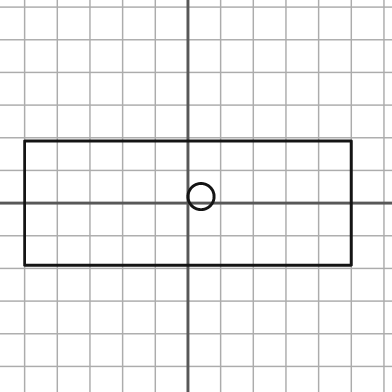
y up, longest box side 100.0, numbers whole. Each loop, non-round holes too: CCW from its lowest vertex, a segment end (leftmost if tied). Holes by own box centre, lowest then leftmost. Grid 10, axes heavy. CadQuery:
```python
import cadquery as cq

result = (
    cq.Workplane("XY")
    .moveTo(-50.0, -19.0)
    .lineTo(50.0, -19.0)
    .lineTo(50.0, 19.0)
    .lineTo(-50.0, 19.0)
    .close()
    .moveTo(4.0, 2.0)
    .circle(4.0)
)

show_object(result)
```